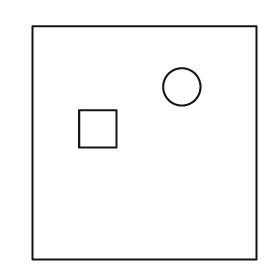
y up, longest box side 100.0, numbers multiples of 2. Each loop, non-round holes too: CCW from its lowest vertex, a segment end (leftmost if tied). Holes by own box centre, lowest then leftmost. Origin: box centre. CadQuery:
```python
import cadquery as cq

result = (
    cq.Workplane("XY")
    .moveTo(-48.0, -50.0)
    .lineTo(48.0, -50.0)
    .lineTo(48.0, 50.0)
    .lineTo(-48.0, 50.0)
    .close()
    .moveTo(-28.0, -2.0)
    .lineTo(-12.0, -2.0)
    .lineTo(-12.0, 14.0)
    .lineTo(-28.0, 14.0)
    .close()
    .moveTo(16.0, 24.0)
    .circle(8.0)
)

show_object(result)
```